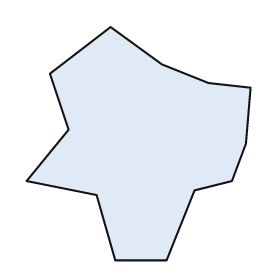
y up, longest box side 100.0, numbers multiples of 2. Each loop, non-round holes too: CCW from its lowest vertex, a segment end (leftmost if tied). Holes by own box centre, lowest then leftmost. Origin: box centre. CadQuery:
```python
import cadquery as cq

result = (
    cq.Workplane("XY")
    .moveTo(-10.0, -50.0)
    .lineTo(12.0, -50.0)
    .lineTo(24.0, -20.0)
    .lineTo(40.0, -16.0)
    .lineTo(46.0, 0.0)
    .lineTo(48.0, 24.0)
    .lineTo(30.0, 26.0)
    .lineTo(10.0, 34.0)
    .lineTo(-12.0, 50.0)
    .lineTo(-38.0, 30.0)
    .lineTo(-30.0, 6.0)
    .lineTo(-48.0, -16.0)
    .lineTo(-18.0, -22.0)
    .close()
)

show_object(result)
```